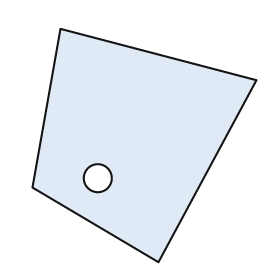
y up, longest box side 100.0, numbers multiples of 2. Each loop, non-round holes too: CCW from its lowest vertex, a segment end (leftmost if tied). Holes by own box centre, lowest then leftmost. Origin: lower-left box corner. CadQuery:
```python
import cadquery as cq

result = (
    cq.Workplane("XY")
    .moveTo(54.0, 0.0)
    .lineTo(96.0, 78.0)
    .lineTo(12.0, 100.0)
    .lineTo(0.0, 32.0)
    .close()
    .moveTo(28.0, 36.0)
    .circle(6.0)
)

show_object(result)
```